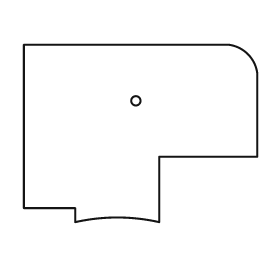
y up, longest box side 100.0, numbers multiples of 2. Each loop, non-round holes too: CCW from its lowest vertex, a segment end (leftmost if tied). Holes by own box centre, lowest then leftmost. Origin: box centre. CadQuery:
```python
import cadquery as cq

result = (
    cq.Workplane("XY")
    .moveTo(-28.0, -38.0)
    .threePointArc((-10.0, -36.0), (8.0, -38.0))
    .lineTo(8.0, -10.0)
    .lineTo(50.0, -10.0)
    .lineTo(50.0, 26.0)
    .threePointArc((46.0, 34.0), (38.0, 38.0))
    .lineTo(-50.0, 38.0)
    .lineTo(-50.0, -32.0)
    .lineTo(-28.0, -32.0)
    .close()
    .moveTo(-2.0, 14.0)
    .circle(2.0)
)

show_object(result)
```